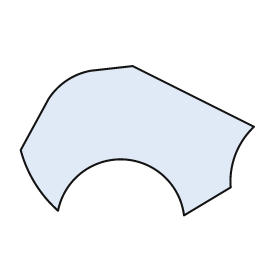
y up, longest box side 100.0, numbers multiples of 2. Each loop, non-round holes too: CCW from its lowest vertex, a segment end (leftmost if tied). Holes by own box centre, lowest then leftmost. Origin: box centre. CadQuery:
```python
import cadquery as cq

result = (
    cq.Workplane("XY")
    .moveTo(20.0, -32.0)
    .lineTo(40.0, -20.0)
    .threePointArc((42.0, -6.0), (50.0, 6.0))
    .lineTo(-2.0, 32.0)
    .lineTo(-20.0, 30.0)
    .threePointArc((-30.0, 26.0), (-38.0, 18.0))
    .lineTo(-50.0, -4.0)
    .threePointArc((-44.0, -18.0), (-34.0, -30.0))
    .threePointArc((-6.0, -8.0), (20.0, -32.0))
    .close()
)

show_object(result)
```